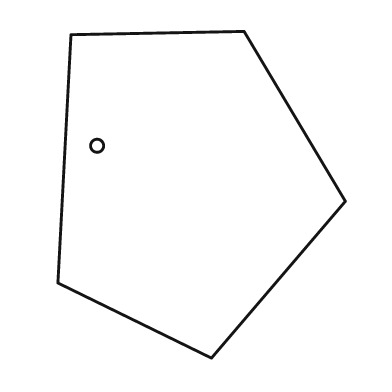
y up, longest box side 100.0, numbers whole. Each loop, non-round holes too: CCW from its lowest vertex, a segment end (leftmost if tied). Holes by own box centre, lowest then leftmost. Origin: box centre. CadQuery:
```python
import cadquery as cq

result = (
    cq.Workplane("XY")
    .moveTo(3.0, -50.0)
    .lineTo(44.0, -2.0)
    .lineTo(13.0, 50.0)
    .lineTo(-40.0, 49.0)
    .lineTo(-44.0, -27.0)
    .close()
    .moveTo(-32.0, 15.0)
    .circle(2.0)
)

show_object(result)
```